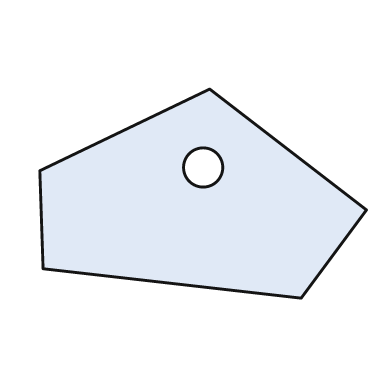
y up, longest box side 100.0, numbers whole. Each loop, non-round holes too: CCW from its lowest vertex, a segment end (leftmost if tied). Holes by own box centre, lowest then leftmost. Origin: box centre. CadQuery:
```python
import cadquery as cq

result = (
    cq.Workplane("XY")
    .moveTo(30.0, -32.0)
    .lineTo(50.0, -5.0)
    .lineTo(2.0, 32.0)
    .lineTo(-50.0, 7.0)
    .lineTo(-49.0, -23.0)
    .close()
    .moveTo(0.0, 8.0)
    .circle(6.0)
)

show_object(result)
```